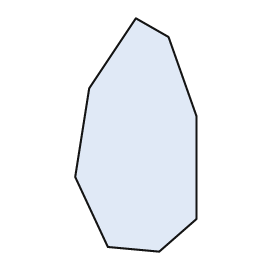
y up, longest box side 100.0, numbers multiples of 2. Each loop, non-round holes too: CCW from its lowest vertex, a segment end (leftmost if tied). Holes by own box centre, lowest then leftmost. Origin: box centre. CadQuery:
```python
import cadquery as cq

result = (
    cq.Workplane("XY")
    .moveTo(10.0, -50.0)
    .lineTo(26.0, -36.0)
    .lineTo(26.0, 8.0)
    .lineTo(14.0, 42.0)
    .lineTo(0.0, 50.0)
    .lineTo(-20.0, 20.0)
    .lineTo(-26.0, -18.0)
    .lineTo(-12.0, -48.0)
    .close()
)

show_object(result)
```